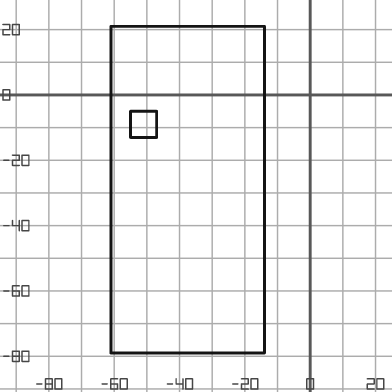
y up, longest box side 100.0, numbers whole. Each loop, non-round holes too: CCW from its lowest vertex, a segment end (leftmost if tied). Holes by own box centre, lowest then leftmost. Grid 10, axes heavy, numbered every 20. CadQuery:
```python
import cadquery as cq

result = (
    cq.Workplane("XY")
    .moveTo(-61.0, -79.0)
    .lineTo(-14.0, -79.0)
    .lineTo(-14.0, 21.0)
    .lineTo(-61.0, 21.0)
    .close()
    .moveTo(-55.0, -13.0)
    .lineTo(-47.0, -13.0)
    .lineTo(-47.0, -5.0)
    .lineTo(-55.0, -5.0)
    .close()
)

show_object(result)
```